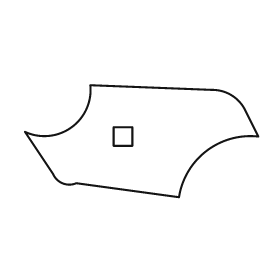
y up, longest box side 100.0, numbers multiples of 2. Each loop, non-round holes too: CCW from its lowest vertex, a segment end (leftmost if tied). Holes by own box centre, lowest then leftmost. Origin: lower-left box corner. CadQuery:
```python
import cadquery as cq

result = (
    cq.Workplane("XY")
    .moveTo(66.0, 0.0)
    .threePointArc((78.0, 20.0), (100.0, 26.0))
    .lineTo(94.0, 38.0)
    .threePointArc((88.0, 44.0), (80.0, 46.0))
    .lineTo(28.0, 48.0)
    .threePointArc((20.0, 30.0), (0.0, 28.0))
    .lineTo(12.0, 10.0)
    .threePointArc((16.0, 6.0), (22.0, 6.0))
    .close()
    .moveTo(38.0, 22.0)
    .lineTo(46.0, 22.0)
    .lineTo(46.0, 30.0)
    .lineTo(38.0, 30.0)
    .close()
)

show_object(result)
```